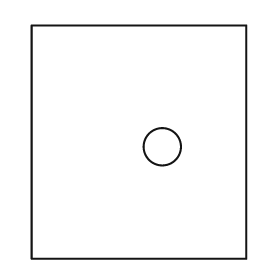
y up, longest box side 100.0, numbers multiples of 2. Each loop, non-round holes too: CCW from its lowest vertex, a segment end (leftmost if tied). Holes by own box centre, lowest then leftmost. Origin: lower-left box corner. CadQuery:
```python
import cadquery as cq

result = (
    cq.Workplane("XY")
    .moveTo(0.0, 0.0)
    .lineTo(92.0, 0.0)
    .lineTo(92.0, 100.0)
    .lineTo(0.0, 100.0)
    .close()
    .moveTo(56.0, 48.0)
    .circle(8.0)
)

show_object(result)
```